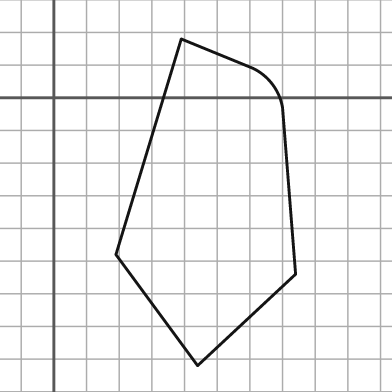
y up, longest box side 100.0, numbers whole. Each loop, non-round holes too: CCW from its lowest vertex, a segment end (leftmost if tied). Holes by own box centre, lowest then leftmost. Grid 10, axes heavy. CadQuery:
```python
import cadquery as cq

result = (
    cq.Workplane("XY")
    .moveTo(44.0, -82.0)
    .lineTo(74.0, -54.0)
    .lineTo(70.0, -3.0)
    .threePointArc((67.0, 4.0), (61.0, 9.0))
    .lineTo(39.0, 18.0)
    .lineTo(19.0, -48.0)
    .close()
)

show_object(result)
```